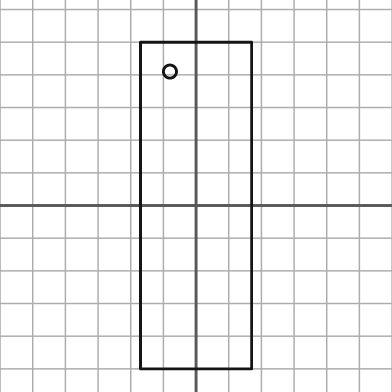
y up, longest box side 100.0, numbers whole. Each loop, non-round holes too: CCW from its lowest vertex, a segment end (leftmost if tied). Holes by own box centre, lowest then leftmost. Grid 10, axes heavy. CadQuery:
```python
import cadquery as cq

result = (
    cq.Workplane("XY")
    .moveTo(-17.0, -50.0)
    .lineTo(17.0, -50.0)
    .lineTo(17.0, 50.0)
    .lineTo(-17.0, 50.0)
    .close()
    .moveTo(-8.0, 41.0)
    .circle(2.0)
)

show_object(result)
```